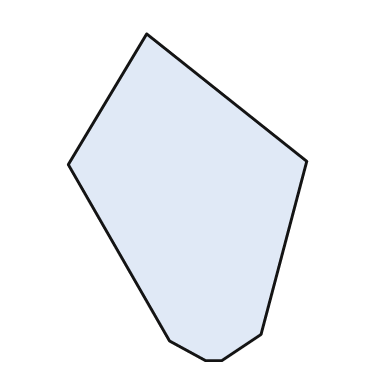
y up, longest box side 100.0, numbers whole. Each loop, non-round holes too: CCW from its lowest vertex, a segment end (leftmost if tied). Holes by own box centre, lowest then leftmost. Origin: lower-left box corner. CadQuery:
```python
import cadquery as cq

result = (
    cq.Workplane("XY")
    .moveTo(42.0, 0.0)
    .lineTo(47.0, 0.0)
    .lineTo(59.0, 8.0)
    .lineTo(73.0, 61.0)
    .lineTo(24.0, 100.0)
    .lineTo(0.0, 60.0)
    .lineTo(31.0, 6.0)
    .close()
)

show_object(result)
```